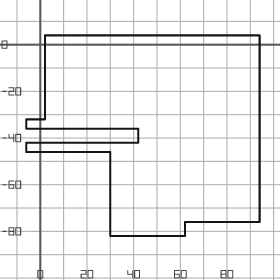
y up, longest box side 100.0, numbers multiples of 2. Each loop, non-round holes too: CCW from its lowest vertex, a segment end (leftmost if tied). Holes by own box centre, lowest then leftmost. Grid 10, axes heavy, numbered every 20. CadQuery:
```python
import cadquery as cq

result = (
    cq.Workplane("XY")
    .moveTo(30.0, -82.0)
    .lineTo(62.0, -82.0)
    .lineTo(62.0, -76.0)
    .lineTo(94.0, -76.0)
    .lineTo(94.0, 4.0)
    .lineTo(2.0, 4.0)
    .lineTo(2.0, -32.0)
    .lineTo(-6.0, -32.0)
    .lineTo(-6.0, -36.0)
    .lineTo(42.0, -36.0)
    .lineTo(42.0, -42.0)
    .lineTo(-6.0, -42.0)
    .lineTo(-6.0, -46.0)
    .lineTo(30.0, -46.0)
    .close()
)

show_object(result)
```